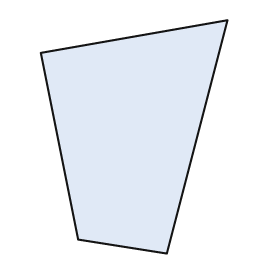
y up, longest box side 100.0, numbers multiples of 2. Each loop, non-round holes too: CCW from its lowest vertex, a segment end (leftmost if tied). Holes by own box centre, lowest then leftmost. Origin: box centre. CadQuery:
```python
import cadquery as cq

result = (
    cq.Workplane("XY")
    .moveTo(14.0, -50.0)
    .lineTo(40.0, 50.0)
    .lineTo(-40.0, 36.0)
    .lineTo(-24.0, -44.0)
    .close()
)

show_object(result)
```